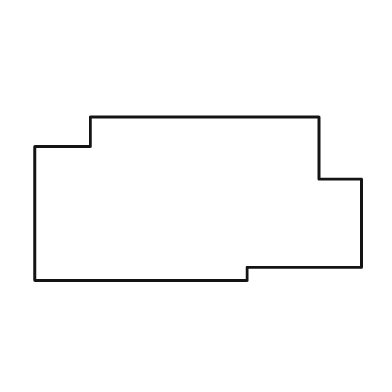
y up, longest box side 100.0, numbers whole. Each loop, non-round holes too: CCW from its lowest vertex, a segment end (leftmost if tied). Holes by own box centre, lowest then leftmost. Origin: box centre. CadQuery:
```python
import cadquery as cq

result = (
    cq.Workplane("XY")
    .moveTo(-50.0, -25.0)
    .lineTo(15.0, -25.0)
    .lineTo(15.0, -21.0)
    .lineTo(50.0, -21.0)
    .lineTo(50.0, 6.0)
    .lineTo(37.0, 6.0)
    .lineTo(37.0, 25.0)
    .lineTo(-33.0, 25.0)
    .lineTo(-33.0, 16.0)
    .lineTo(-50.0, 16.0)
    .close()
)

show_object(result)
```